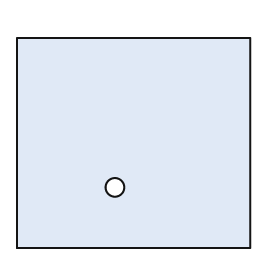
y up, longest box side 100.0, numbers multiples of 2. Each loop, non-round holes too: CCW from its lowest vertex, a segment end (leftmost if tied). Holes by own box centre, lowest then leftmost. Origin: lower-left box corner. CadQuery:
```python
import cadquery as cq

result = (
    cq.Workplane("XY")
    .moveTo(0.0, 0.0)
    .lineTo(100.0, 0.0)
    .lineTo(100.0, 90.0)
    .lineTo(0.0, 90.0)
    .close()
    .moveTo(42.0, 26.0)
    .circle(4.0)
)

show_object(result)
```